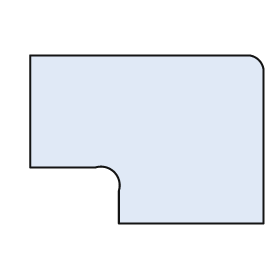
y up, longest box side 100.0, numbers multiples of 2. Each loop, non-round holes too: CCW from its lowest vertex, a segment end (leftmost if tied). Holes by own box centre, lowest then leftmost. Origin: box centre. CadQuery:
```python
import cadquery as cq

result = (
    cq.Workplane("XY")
    .moveTo(-12.0, -36.0)
    .lineTo(50.0, -36.0)
    .lineTo(50.0, 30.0)
    .threePointArc((48.0, 34.0), (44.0, 36.0))
    .lineTo(-50.0, 36.0)
    .lineTo(-50.0, -12.0)
    .lineTo(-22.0, -12.0)
    .threePointArc((-14.0, -14.0), (-12.0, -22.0))
    .close()
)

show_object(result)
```